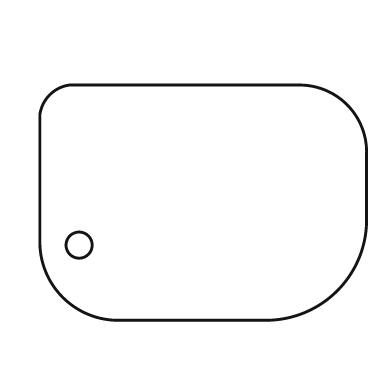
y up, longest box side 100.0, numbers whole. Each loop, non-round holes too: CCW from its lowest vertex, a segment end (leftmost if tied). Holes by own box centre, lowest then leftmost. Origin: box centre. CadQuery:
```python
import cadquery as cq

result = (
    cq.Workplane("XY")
    .moveTo(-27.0, -36.0)
    .lineTo(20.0, -36.0)
    .threePointArc((41.0, -27.0), (50.0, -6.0))
    .lineTo(50.0, 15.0)
    .threePointArc((44.0, 30.0), (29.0, 36.0))
    .lineTo(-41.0, 36.0)
    .threePointArc((-47.0, 33.0), (-50.0, 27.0))
    .lineTo(-50.0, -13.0)
    .threePointArc((-43.0, -29.0), (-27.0, -36.0))
    .close()
    .moveTo(-38.0, -13.0)
    .circle(4.0)
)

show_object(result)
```